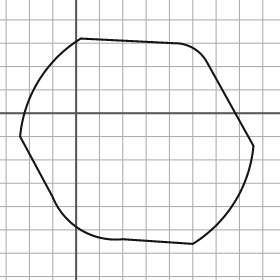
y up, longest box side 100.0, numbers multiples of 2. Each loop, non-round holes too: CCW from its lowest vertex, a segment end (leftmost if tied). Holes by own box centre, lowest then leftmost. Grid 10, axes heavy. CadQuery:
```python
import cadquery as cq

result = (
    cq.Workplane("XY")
    .moveTo(50.0, -56.0)
    .threePointArc((68.0, -38.0), (76.0, -14.0))
    .lineTo(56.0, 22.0)
    .threePointArc((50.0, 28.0), (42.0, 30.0))
    .lineTo(2.0, 32.0)
    .threePointArc((-16.0, 14.0), (-24.0, -10.0))
    .lineTo(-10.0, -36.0)
    .threePointArc((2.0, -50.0), (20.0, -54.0))
    .close()
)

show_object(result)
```